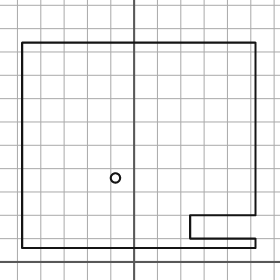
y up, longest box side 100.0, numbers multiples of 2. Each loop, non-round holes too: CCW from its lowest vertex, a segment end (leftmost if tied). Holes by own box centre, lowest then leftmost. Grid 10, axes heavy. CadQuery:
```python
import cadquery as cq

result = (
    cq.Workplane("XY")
    .moveTo(-48.0, 6.0)
    .lineTo(52.0, 6.0)
    .lineTo(52.0, 10.0)
    .lineTo(24.0, 10.0)
    .lineTo(24.0, 20.0)
    .lineTo(52.0, 20.0)
    .lineTo(52.0, 94.0)
    .lineTo(-48.0, 94.0)
    .close()
    .moveTo(-8.0, 36.0)
    .circle(2.0)
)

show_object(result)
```